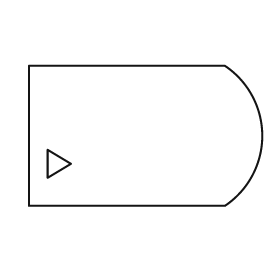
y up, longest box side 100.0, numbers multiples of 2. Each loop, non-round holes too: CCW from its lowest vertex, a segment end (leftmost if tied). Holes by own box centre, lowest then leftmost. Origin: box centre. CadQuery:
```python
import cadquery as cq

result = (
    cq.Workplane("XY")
    .moveTo(-50.0, -30.0)
    .lineTo(34.0, -30.0)
    .threePointArc((50.0, 0.0), (34.0, 30.0))
    .lineTo(-50.0, 30.0)
    .close()
    .moveTo(-42.0, -18.0)
    .lineTo(-32.0, -12.0)
    .lineTo(-42.0, -6.0)
    .close()
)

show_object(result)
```